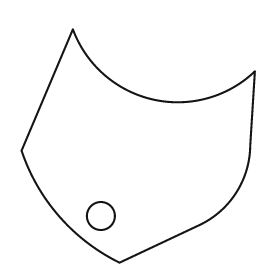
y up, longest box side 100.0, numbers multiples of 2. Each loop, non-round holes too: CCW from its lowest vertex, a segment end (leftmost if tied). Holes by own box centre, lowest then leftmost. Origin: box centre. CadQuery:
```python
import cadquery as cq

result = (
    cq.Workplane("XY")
    .moveTo(-8.0, -50.0)
    .lineTo(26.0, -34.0)
    .threePointArc((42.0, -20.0), (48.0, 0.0))
    .lineTo(50.0, 32.0)
    .threePointArc((6.0, 20.0), (-28.0, 50.0))
    .lineTo(-50.0, -2.0)
    .threePointArc((-34.0, -30.0), (-8.0, -50.0))
    .close()
    .moveTo(-16.0, -30.0)
    .circle(6.0)
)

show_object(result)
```